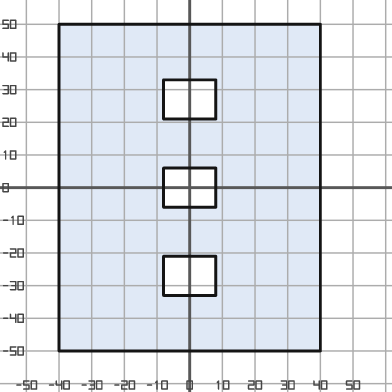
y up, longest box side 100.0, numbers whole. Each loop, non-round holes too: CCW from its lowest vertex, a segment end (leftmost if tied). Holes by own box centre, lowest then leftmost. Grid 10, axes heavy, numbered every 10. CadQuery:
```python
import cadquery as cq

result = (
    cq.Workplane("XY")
    .moveTo(-40.0, -50.0)
    .lineTo(40.0, -50.0)
    .lineTo(40.0, 50.0)
    .lineTo(-40.0, 50.0)
    .close()
    .moveTo(-8.0, -33.0)
    .lineTo(8.0, -33.0)
    .lineTo(8.0, -21.0)
    .lineTo(-8.0, -21.0)
    .close()
    .moveTo(-8.0, -6.0)
    .lineTo(8.0, -6.0)
    .lineTo(8.0, 6.0)
    .lineTo(-8.0, 6.0)
    .close()
    .moveTo(-8.0, 21.0)
    .lineTo(8.0, 21.0)
    .lineTo(8.0, 33.0)
    .lineTo(-8.0, 33.0)
    .close()
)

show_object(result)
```